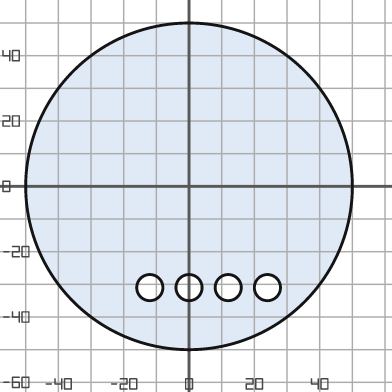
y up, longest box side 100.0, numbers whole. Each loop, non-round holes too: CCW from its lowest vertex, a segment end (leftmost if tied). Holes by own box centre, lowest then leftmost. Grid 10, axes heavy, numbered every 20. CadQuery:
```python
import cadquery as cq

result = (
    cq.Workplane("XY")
    .moveTo(0.0, 0.0)
    .circle(50.0)
    .moveTo(-12.0, -31.0)
    .circle(4.0)
    .moveTo(0.0, -31.0)
    .circle(4.0)
    .moveTo(12.0, -31.0)
    .circle(4.0)
    .moveTo(24.0, -31.0)
    .circle(4.0)
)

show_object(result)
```